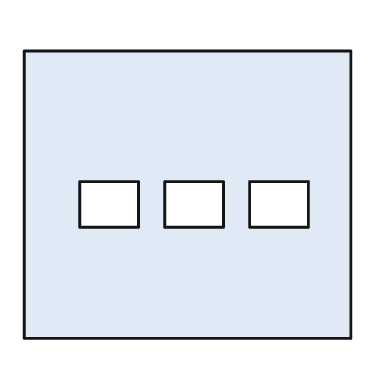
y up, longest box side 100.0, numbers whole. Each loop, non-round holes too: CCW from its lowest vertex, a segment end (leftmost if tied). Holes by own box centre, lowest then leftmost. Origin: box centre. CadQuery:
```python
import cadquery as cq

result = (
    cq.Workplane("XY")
    .moveTo(-50.0, -44.0)
    .lineTo(50.0, -44.0)
    .lineTo(50.0, 44.0)
    .lineTo(-50.0, 44.0)
    .close()
    .moveTo(-33.0, -10.0)
    .lineTo(-15.0, -10.0)
    .lineTo(-15.0, 4.0)
    .lineTo(-33.0, 4.0)
    .close()
    .moveTo(-7.0, -10.0)
    .lineTo(11.0, -10.0)
    .lineTo(11.0, 4.0)
    .lineTo(-7.0, 4.0)
    .close()
    .moveTo(19.0, -10.0)
    .lineTo(37.0, -10.0)
    .lineTo(37.0, 4.0)
    .lineTo(19.0, 4.0)
    .close()
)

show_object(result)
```